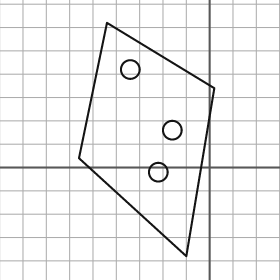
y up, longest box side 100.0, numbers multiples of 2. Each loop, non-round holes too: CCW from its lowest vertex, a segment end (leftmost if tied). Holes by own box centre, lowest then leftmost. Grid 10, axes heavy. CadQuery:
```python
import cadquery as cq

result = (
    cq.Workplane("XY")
    .moveTo(-10.0, -38.0)
    .lineTo(2.0, 34.0)
    .lineTo(-44.0, 62.0)
    .lineTo(-56.0, 4.0)
    .close()
    .moveTo(-22.0, -2.0)
    .circle(4.0)
    .moveTo(-16.0, 16.0)
    .circle(4.0)
    .moveTo(-34.0, 42.0)
    .circle(4.0)
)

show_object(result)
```